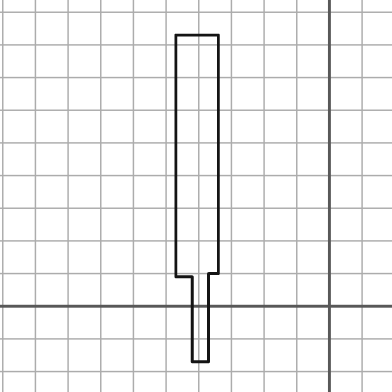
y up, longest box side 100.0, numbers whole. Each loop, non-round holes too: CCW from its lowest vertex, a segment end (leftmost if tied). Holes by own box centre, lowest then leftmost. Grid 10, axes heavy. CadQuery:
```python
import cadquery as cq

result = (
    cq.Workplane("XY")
    .moveTo(-42.0, -17.0)
    .lineTo(-37.0, -17.0)
    .lineTo(-37.0, 10.0)
    .lineTo(-34.0, 10.0)
    .lineTo(-34.0, 83.0)
    .lineTo(-47.0, 83.0)
    .lineTo(-47.0, 9.0)
    .lineTo(-42.0, 9.0)
    .close()
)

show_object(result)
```